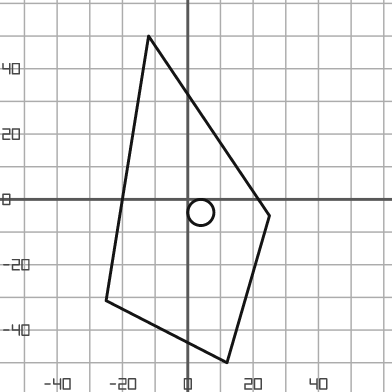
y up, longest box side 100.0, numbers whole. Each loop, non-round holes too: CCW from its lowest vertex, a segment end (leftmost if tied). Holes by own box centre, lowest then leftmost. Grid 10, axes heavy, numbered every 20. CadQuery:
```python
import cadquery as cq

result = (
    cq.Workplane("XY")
    .moveTo(12.0, -50.0)
    .lineTo(25.0, -5.0)
    .lineTo(-12.0, 50.0)
    .lineTo(-25.0, -31.0)
    .close()
    .moveTo(4.0, -4.0)
    .circle(4.0)
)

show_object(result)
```